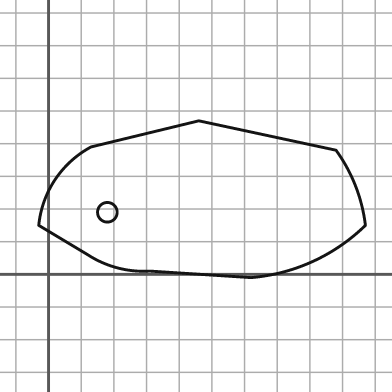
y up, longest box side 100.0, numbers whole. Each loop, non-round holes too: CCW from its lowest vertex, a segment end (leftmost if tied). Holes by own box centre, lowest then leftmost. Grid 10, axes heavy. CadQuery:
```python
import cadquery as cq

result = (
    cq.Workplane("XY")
    .moveTo(62.0, -1.0)
    .threePointArc((81.0, 4.0), (97.0, 15.0))
    .threePointArc((94.0, 27.0), (88.0, 38.0))
    .lineTo(46.0, 47.0)
    .lineTo(13.0, 39.0)
    .threePointArc((2.0, 29.0), (-3.0, 15.0))
    .lineTo(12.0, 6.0)
    .threePointArc((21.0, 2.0), (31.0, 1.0))
    .close()
    .moveTo(18.0, 19.0)
    .circle(3.0)
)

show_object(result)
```